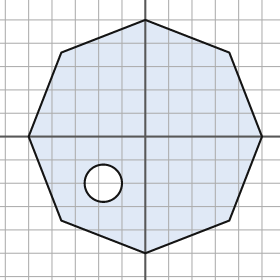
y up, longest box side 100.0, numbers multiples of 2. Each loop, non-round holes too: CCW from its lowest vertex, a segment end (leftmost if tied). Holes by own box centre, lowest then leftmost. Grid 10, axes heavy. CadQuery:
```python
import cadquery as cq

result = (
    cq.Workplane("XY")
    .moveTo(0.0, -50.0)
    .lineTo(36.0, -36.0)
    .lineTo(50.0, 0.0)
    .lineTo(36.0, 36.0)
    .lineTo(0.0, 50.0)
    .lineTo(-36.0, 36.0)
    .lineTo(-50.0, 0.0)
    .lineTo(-36.0, -36.0)
    .close()
    .moveTo(-18.0, -20.0)
    .circle(8.0)
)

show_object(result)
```